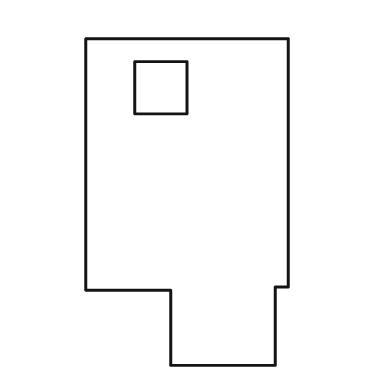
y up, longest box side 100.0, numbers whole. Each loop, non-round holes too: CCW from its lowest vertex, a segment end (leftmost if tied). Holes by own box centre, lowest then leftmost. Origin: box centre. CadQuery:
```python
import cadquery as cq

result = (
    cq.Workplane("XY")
    .moveTo(-5.0, -50.0)
    .lineTo(27.0, -50.0)
    .lineTo(27.0, -26.0)
    .lineTo(31.0, -26.0)
    .lineTo(31.0, 50.0)
    .lineTo(-31.0, 50.0)
    .lineTo(-31.0, -27.0)
    .lineTo(-5.0, -27.0)
    .close()
    .moveTo(-16.0, 27.0)
    .lineTo(0.0, 27.0)
    .lineTo(0.0, 43.0)
    .lineTo(-16.0, 43.0)
    .close()
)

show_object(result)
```